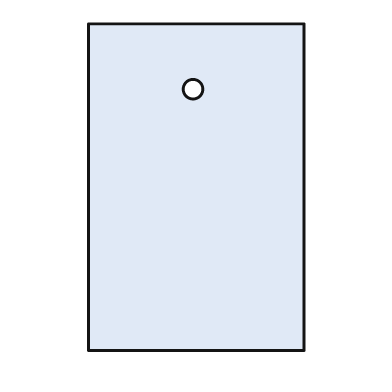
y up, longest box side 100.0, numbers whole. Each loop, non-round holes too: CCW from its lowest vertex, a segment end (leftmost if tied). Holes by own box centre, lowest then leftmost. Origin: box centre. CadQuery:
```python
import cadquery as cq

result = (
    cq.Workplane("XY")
    .moveTo(-33.0, -50.0)
    .lineTo(33.0, -50.0)
    .lineTo(33.0, 50.0)
    .lineTo(-33.0, 50.0)
    .close()
    .moveTo(-1.0, 30.0)
    .circle(3.0)
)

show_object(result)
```